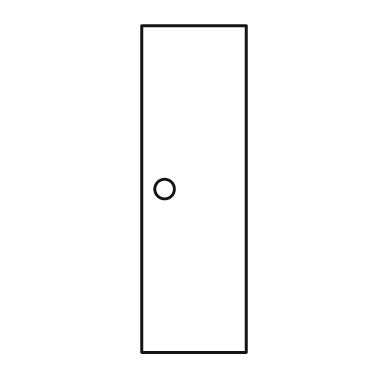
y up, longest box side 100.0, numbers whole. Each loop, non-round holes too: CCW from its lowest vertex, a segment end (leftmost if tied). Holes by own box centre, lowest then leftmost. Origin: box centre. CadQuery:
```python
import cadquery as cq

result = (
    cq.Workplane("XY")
    .moveTo(-16.0, -50.0)
    .lineTo(16.0, -50.0)
    .lineTo(16.0, 50.0)
    .lineTo(-16.0, 50.0)
    .close()
    .moveTo(-9.0, 0.0)
    .circle(3.0)
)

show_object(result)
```